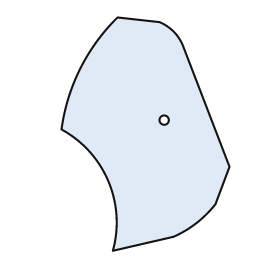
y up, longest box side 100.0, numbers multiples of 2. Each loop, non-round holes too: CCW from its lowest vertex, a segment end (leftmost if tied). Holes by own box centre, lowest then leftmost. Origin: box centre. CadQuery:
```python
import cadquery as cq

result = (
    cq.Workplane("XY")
    .moveTo(-14.0, -50.0)
    .lineTo(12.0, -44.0)
    .threePointArc((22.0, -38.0), (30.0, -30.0))
    .lineTo(36.0, -14.0)
    .lineTo(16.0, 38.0)
    .threePointArc((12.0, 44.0), (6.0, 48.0))
    .lineTo(-12.0, 50.0)
    .threePointArc((-28.0, 28.0), (-36.0, 2.0))
    .threePointArc((-16.0, -20.0), (-14.0, -50.0))
    .close()
    .moveTo(8.0, 6.0)
    .circle(2.0)
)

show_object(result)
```